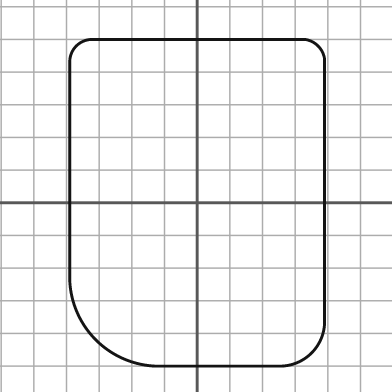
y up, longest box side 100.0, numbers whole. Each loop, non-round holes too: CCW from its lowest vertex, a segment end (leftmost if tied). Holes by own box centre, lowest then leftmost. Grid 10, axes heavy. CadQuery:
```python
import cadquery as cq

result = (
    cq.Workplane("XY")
    .moveTo(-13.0, -50.0)
    .lineTo(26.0, -50.0)
    .threePointArc((35.0, -46.0), (39.0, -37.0))
    .lineTo(39.0, 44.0)
    .threePointArc((37.0, 48.0), (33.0, 50.0))
    .lineTo(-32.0, 50.0)
    .threePointArc((-37.0, 48.0), (-39.0, 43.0))
    .lineTo(-39.0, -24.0)
    .threePointArc((-31.0, -42.0), (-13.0, -50.0))
    .close()
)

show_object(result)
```